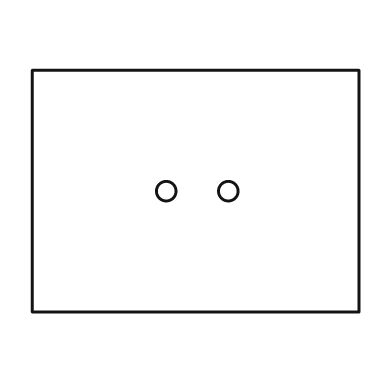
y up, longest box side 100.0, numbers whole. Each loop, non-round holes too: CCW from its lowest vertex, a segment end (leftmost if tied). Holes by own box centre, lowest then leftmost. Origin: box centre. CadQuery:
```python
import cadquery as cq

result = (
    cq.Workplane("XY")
    .moveTo(-50.0, -37.0)
    .lineTo(50.0, -37.0)
    .lineTo(50.0, 37.0)
    .lineTo(-50.0, 37.0)
    .close()
    .moveTo(-9.0, 0.0)
    .circle(3.0)
    .moveTo(10.0, 0.0)
    .circle(3.0)
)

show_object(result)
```